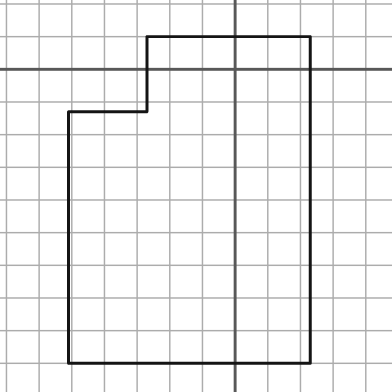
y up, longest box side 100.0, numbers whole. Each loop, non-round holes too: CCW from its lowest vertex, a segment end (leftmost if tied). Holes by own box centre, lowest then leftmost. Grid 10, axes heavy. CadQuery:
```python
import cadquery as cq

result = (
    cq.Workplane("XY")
    .moveTo(-51.0, -90.0)
    .lineTo(23.0, -90.0)
    .lineTo(23.0, 10.0)
    .lineTo(-27.0, 10.0)
    .lineTo(-27.0, -13.0)
    .lineTo(-51.0, -13.0)
    .close()
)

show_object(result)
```